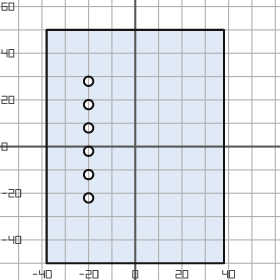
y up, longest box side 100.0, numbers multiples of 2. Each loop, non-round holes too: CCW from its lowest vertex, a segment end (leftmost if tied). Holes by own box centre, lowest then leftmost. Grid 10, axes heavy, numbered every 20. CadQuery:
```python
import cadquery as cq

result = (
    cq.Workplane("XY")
    .moveTo(-38.0, -50.0)
    .lineTo(38.0, -50.0)
    .lineTo(38.0, 50.0)
    .lineTo(-38.0, 50.0)
    .close()
    .moveTo(-20.0, -22.0)
    .circle(2.0)
    .moveTo(-20.0, -12.0)
    .circle(2.0)
    .moveTo(-20.0, -2.0)
    .circle(2.0)
    .moveTo(-20.0, 8.0)
    .circle(2.0)
    .moveTo(-20.0, 18.0)
    .circle(2.0)
    .moveTo(-20.0, 28.0)
    .circle(2.0)
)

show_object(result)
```